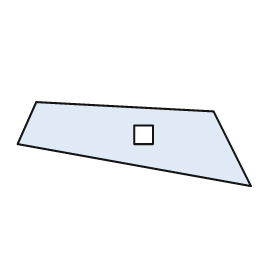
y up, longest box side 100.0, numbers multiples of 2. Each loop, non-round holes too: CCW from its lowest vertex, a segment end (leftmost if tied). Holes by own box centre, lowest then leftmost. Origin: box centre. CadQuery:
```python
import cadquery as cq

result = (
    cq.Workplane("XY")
    .moveTo(50.0, -18.0)
    .lineTo(34.0, 14.0)
    .lineTo(-42.0, 18.0)
    .lineTo(-50.0, 0.0)
    .close()
    .moveTo(0.0, 0.0)
    .lineTo(8.0, 0.0)
    .lineTo(8.0, 8.0)
    .lineTo(0.0, 8.0)
    .close()
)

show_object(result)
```